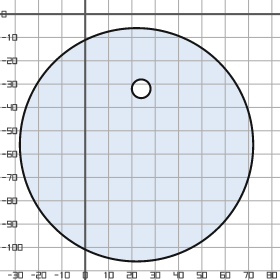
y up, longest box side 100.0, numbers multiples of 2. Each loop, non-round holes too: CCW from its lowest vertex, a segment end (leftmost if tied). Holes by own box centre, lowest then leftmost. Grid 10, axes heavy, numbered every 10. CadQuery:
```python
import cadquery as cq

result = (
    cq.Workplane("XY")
    .moveTo(22.0, -56.0)
    .circle(50.0)
    .moveTo(24.0, -32.0)
    .circle(4.0)
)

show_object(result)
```